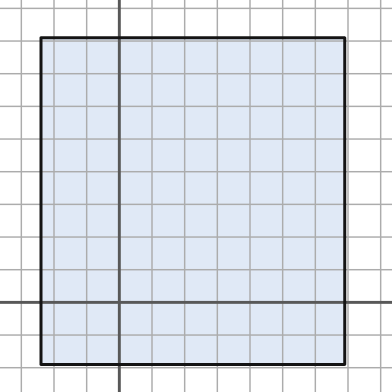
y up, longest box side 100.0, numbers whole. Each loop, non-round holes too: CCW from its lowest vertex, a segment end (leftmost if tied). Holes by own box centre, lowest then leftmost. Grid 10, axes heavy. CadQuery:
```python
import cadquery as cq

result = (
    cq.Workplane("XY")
    .moveTo(-24.0, -19.0)
    .lineTo(69.0, -19.0)
    .lineTo(69.0, 81.0)
    .lineTo(-24.0, 81.0)
    .close()
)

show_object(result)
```